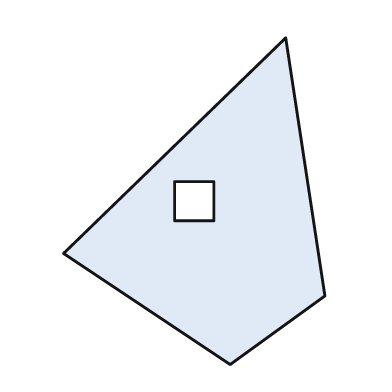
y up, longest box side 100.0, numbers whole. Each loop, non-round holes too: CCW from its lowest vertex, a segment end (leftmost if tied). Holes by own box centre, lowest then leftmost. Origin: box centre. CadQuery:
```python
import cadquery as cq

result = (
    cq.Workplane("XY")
    .moveTo(11.0, -50.0)
    .lineTo(40.0, -29.0)
    .lineTo(28.0, 50.0)
    .lineTo(-40.0, -16.0)
    .close()
    .moveTo(-6.0, -6.0)
    .lineTo(6.0, -6.0)
    .lineTo(6.0, 6.0)
    .lineTo(-6.0, 6.0)
    .close()
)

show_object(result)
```